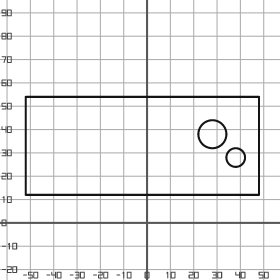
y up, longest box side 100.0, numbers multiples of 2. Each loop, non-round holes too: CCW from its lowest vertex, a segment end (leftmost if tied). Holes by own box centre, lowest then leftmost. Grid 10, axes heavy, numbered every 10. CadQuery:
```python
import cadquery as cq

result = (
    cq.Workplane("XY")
    .moveTo(-52.0, 12.0)
    .lineTo(48.0, 12.0)
    .lineTo(48.0, 54.0)
    .lineTo(-52.0, 54.0)
    .close()
    .moveTo(38.0, 28.0)
    .circle(4.0)
    .moveTo(28.0, 38.0)
    .circle(6.0)
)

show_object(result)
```